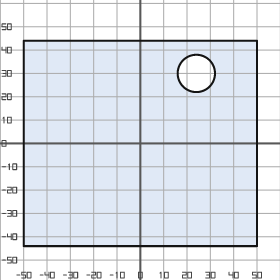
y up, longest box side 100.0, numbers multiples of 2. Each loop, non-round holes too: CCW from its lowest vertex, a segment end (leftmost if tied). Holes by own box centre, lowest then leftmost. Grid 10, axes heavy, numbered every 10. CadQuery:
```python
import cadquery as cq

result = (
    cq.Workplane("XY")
    .moveTo(-50.0, -44.0)
    .lineTo(50.0, -44.0)
    .lineTo(50.0, 44.0)
    .lineTo(-50.0, 44.0)
    .close()
    .moveTo(24.0, 30.0)
    .circle(8.0)
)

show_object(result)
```